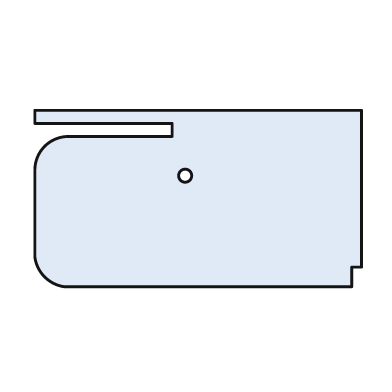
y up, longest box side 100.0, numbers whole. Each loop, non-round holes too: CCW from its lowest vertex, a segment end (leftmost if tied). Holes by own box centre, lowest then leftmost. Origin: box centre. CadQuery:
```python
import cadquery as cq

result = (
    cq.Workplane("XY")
    .moveTo(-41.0, -27.0)
    .lineTo(47.0, -27.0)
    .lineTo(47.0, -21.0)
    .lineTo(50.0, -21.0)
    .lineTo(50.0, 27.0)
    .lineTo(-50.0, 27.0)
    .lineTo(-50.0, 23.0)
    .lineTo(-8.0, 23.0)
    .lineTo(-8.0, 19.0)
    .lineTo(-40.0, 19.0)
    .threePointArc((-47.0, 16.0), (-50.0, 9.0))
    .lineTo(-50.0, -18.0)
    .threePointArc((-47.0, -24.0), (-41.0, -27.0))
    .close()
    .moveTo(-4.0, 7.0)
    .circle(2.0)
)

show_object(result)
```